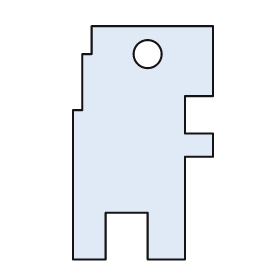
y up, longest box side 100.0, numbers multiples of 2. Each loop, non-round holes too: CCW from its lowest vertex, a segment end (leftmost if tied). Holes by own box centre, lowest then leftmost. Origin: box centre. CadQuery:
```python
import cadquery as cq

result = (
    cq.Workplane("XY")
    .moveTo(-30.0, -50.0)
    .lineTo(-16.0, -50.0)
    .lineTo(-16.0, -30.0)
    .lineTo(2.0, -30.0)
    .lineTo(2.0, -50.0)
    .lineTo(18.0, -50.0)
    .lineTo(18.0, -6.0)
    .lineTo(30.0, -6.0)
    .lineTo(30.0, 4.0)
    .lineTo(18.0, 4.0)
    .lineTo(18.0, 20.0)
    .lineTo(30.0, 20.0)
    .lineTo(30.0, 50.0)
    .lineTo(-22.0, 50.0)
    .lineTo(-22.0, 38.0)
    .lineTo(-26.0, 38.0)
    .lineTo(-26.0, 14.0)
    .lineTo(-30.0, 14.0)
    .close()
    .moveTo(2.0, 38.0)
    .circle(6.0)
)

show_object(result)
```